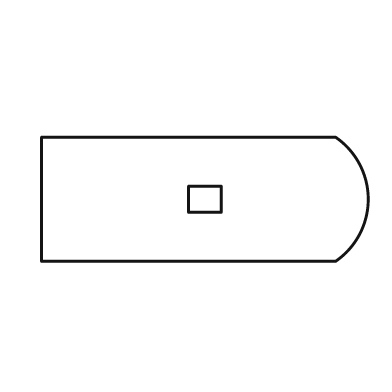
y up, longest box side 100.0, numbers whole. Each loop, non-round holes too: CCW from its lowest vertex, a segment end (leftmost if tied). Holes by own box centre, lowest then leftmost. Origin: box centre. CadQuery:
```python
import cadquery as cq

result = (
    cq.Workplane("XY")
    .moveTo(-50.0, -19.0)
    .lineTo(40.0, -19.0)
    .threePointArc((50.0, 0.0), (40.0, 19.0))
    .lineTo(-50.0, 19.0)
    .close()
    .moveTo(-5.0, -4.0)
    .lineTo(5.0, -4.0)
    .lineTo(5.0, 4.0)
    .lineTo(-5.0, 4.0)
    .close()
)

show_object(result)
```